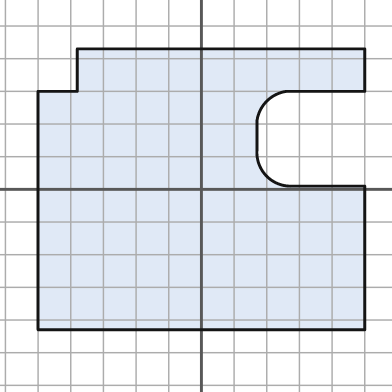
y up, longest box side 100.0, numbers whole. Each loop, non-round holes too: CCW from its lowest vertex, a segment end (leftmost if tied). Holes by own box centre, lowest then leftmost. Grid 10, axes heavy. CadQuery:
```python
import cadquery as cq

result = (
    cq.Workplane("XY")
    .moveTo(-50.0, -43.0)
    .lineTo(50.0, -43.0)
    .lineTo(50.0, 1.0)
    .lineTo(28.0, 1.0)
    .threePointArc((20.0, 4.0), (17.0, 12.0))
    .lineTo(17.0, 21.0)
    .threePointArc((20.0, 27.0), (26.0, 30.0))
    .lineTo(50.0, 30.0)
    .lineTo(50.0, 43.0)
    .lineTo(-38.0, 43.0)
    .lineTo(-38.0, 30.0)
    .lineTo(-50.0, 30.0)
    .close()
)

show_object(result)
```